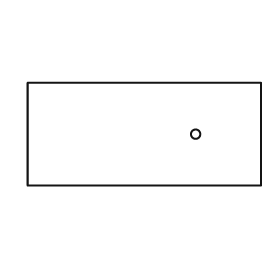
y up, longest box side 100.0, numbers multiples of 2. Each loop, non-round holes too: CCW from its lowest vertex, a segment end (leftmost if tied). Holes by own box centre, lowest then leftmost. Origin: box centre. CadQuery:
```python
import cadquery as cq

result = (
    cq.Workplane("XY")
    .moveTo(-50.0, -22.0)
    .lineTo(50.0, -22.0)
    .lineTo(50.0, 22.0)
    .lineTo(-50.0, 22.0)
    .close()
    .moveTo(22.0, 0.0)
    .circle(2.0)
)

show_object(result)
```